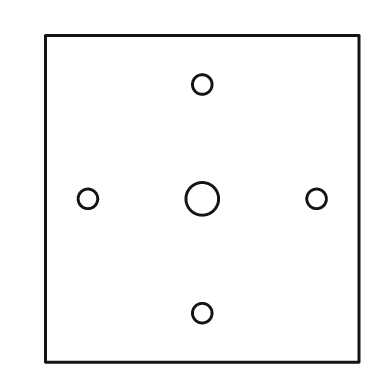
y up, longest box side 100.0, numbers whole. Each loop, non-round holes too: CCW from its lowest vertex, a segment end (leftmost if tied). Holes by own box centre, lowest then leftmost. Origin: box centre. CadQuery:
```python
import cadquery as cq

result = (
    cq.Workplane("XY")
    .moveTo(-48.0, -50.0)
    .lineTo(48.0, -50.0)
    .lineTo(48.0, 50.0)
    .lineTo(-48.0, 50.0)
    .close()
    .moveTo(0.0, -35.0)
    .circle(3.0)
    .moveTo(-35.0, 0.0)
    .circle(3.0)
    .moveTo(0.0, 0.0)
    .circle(5.0)
    .moveTo(35.0, 0.0)
    .circle(3.0)
    .moveTo(0.0, 35.0)
    .circle(3.0)
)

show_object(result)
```